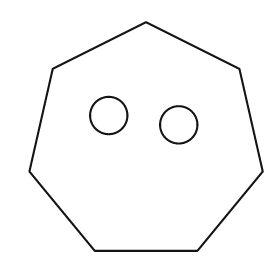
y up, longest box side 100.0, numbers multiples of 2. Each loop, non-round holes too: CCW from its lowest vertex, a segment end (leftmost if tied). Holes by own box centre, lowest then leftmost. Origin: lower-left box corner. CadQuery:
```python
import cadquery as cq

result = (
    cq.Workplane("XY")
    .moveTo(28.0, 0.0)
    .lineTo(72.0, 0.0)
    .lineTo(100.0, 34.0)
    .lineTo(90.0, 78.0)
    .lineTo(50.0, 98.0)
    .lineTo(10.0, 78.0)
    .lineTo(0.0, 34.0)
    .close()
    .moveTo(64.0, 54.0)
    .circle(8.0)
    .moveTo(34.0, 58.0)
    .circle(8.0)
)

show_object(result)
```